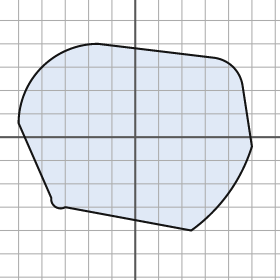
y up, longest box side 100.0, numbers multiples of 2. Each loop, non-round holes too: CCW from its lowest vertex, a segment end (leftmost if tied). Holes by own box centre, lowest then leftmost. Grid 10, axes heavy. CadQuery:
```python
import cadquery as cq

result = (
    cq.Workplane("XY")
    .moveTo(24.0, -40.0)
    .threePointArc((40.0, -24.0), (50.0, -4.0))
    .lineTo(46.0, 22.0)
    .threePointArc((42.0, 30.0), (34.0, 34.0))
    .lineTo(-16.0, 40.0)
    .threePointArc((-40.0, 30.0), (-50.0, 6.0))
    .lineTo(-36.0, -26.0)
    .threePointArc((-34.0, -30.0), (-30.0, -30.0))
    .close()
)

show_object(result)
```